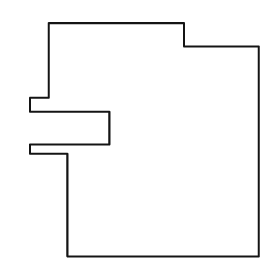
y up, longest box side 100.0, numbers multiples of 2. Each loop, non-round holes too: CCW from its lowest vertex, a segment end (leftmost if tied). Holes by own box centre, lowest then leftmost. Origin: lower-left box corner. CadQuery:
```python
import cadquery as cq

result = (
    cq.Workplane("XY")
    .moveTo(16.0, 0.0)
    .lineTo(98.0, 0.0)
    .lineTo(98.0, 90.0)
    .lineTo(66.0, 90.0)
    .lineTo(66.0, 100.0)
    .lineTo(8.0, 100.0)
    .lineTo(8.0, 68.0)
    .lineTo(0.0, 68.0)
    .lineTo(0.0, 62.0)
    .lineTo(34.0, 62.0)
    .lineTo(34.0, 48.0)
    .lineTo(0.0, 48.0)
    .lineTo(0.0, 44.0)
    .lineTo(16.0, 44.0)
    .close()
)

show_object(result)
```